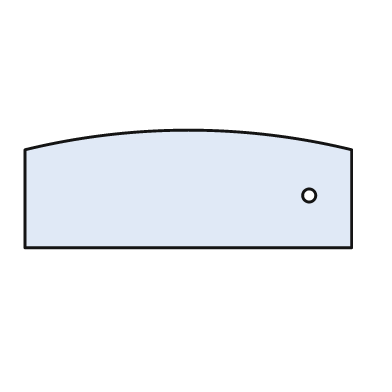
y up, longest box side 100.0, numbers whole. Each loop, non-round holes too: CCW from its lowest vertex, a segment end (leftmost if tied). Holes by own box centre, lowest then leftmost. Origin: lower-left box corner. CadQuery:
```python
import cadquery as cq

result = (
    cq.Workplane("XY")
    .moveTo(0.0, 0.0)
    .lineTo(100.0, 0.0)
    .lineTo(100.0, 30.0)
    .threePointArc((50.0, 36.0), (0.0, 30.0))
    .close()
    .moveTo(87.0, 16.0)
    .circle(2.0)
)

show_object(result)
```